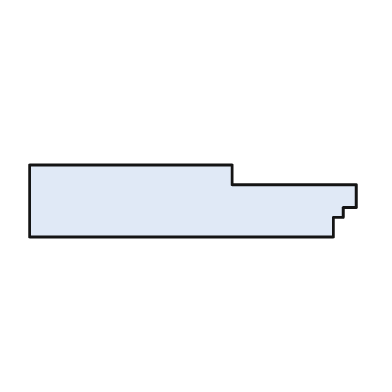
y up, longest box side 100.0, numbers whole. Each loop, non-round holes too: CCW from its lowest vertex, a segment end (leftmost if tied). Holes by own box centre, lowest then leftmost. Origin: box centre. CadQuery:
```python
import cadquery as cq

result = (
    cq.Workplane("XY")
    .moveTo(-50.0, -11.0)
    .lineTo(43.0, -11.0)
    .lineTo(43.0, -5.0)
    .lineTo(46.0, -5.0)
    .lineTo(46.0, -2.0)
    .lineTo(50.0, -2.0)
    .lineTo(50.0, 5.0)
    .lineTo(12.0, 5.0)
    .lineTo(12.0, 11.0)
    .lineTo(-50.0, 11.0)
    .close()
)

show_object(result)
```